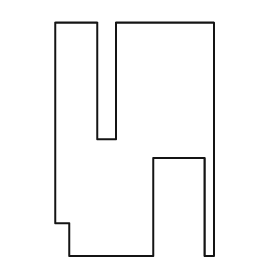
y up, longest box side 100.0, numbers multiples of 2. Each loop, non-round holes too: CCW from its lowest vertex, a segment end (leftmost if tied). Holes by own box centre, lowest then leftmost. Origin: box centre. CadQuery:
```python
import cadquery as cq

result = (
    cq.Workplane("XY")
    .moveTo(-28.0, -50.0)
    .lineTo(8.0, -50.0)
    .lineTo(8.0, -8.0)
    .lineTo(30.0, -8.0)
    .lineTo(30.0, -50.0)
    .lineTo(34.0, -50.0)
    .lineTo(34.0, 50.0)
    .lineTo(-8.0, 50.0)
    .lineTo(-8.0, 0.0)
    .lineTo(-16.0, 0.0)
    .lineTo(-16.0, 50.0)
    .lineTo(-34.0, 50.0)
    .lineTo(-34.0, -36.0)
    .lineTo(-28.0, -36.0)
    .close()
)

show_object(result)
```